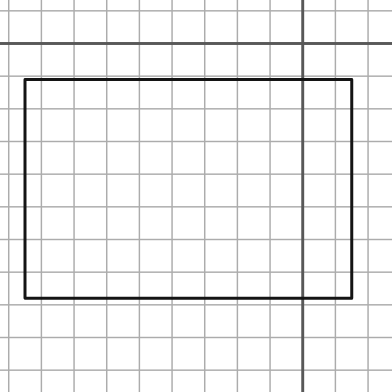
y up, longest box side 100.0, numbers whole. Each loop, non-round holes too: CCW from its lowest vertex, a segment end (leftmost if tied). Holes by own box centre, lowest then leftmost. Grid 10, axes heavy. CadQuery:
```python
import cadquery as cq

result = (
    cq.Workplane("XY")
    .moveTo(-85.0, -78.0)
    .lineTo(15.0, -78.0)
    .lineTo(15.0, -11.0)
    .lineTo(-85.0, -11.0)
    .close()
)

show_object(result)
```